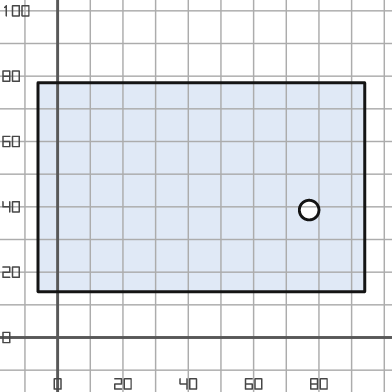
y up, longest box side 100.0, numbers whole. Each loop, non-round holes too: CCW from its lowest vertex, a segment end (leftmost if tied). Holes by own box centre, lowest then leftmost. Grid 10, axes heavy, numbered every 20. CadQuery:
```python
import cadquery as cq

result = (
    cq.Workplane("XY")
    .moveTo(-6.0, 14.0)
    .lineTo(94.0, 14.0)
    .lineTo(94.0, 78.0)
    .lineTo(-6.0, 78.0)
    .close()
    .moveTo(77.0, 39.0)
    .circle(3.0)
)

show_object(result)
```